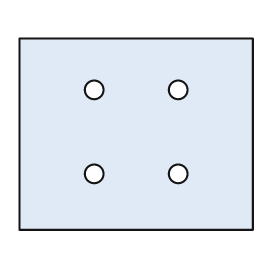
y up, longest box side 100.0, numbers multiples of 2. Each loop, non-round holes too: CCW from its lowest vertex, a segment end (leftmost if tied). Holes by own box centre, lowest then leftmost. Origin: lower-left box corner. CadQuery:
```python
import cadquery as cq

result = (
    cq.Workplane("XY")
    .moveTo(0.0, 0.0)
    .lineTo(100.0, 0.0)
    .lineTo(100.0, 82.0)
    .lineTo(0.0, 82.0)
    .close()
    .moveTo(32.0, 24.0)
    .circle(4.0)
    .moveTo(68.0, 24.0)
    .circle(4.0)
    .moveTo(32.0, 60.0)
    .circle(4.0)
    .moveTo(68.0, 60.0)
    .circle(4.0)
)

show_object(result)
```